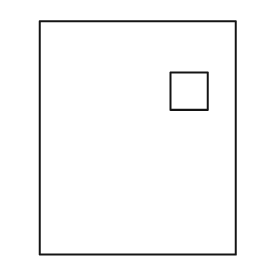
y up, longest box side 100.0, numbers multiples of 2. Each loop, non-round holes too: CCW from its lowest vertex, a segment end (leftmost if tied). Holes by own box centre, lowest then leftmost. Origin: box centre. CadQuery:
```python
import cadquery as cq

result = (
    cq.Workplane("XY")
    .moveTo(-42.0, -50.0)
    .lineTo(42.0, -50.0)
    .lineTo(42.0, 50.0)
    .lineTo(-42.0, 50.0)
    .close()
    .moveTo(14.0, 12.0)
    .lineTo(30.0, 12.0)
    .lineTo(30.0, 28.0)
    .lineTo(14.0, 28.0)
    .close()
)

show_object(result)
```